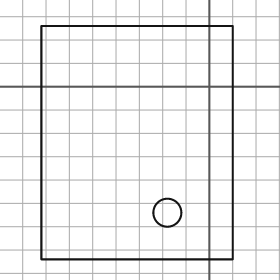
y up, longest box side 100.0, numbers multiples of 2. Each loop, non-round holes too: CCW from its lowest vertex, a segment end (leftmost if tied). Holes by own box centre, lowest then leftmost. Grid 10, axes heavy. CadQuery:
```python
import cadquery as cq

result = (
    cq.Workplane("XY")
    .moveTo(-72.0, -74.0)
    .lineTo(10.0, -74.0)
    .lineTo(10.0, 26.0)
    .lineTo(-72.0, 26.0)
    .close()
    .moveTo(-18.0, -54.0)
    .circle(6.0)
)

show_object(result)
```